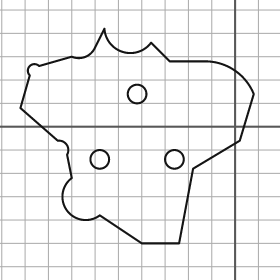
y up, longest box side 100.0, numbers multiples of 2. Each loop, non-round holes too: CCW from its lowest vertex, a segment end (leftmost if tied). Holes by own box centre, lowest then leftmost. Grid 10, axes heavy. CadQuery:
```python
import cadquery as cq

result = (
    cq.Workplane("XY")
    .moveTo(-40.0, -50.0)
    .lineTo(-24.0, -50.0)
    .lineTo(-18.0, -18.0)
    .lineTo(2.0, -6.0)
    .lineTo(8.0, 14.0)
    .threePointArc((0.0, 24.0), (-12.0, 28.0))
    .lineTo(-28.0, 28.0)
    .lineTo(-36.0, 36.0)
    .threePointArc((-48.0, 32.0), (-56.0, 42.0))
    .lineTo(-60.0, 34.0)
    .threePointArc((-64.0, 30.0), (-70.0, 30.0))
    .lineTo(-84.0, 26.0)
    .threePointArc((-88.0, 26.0), (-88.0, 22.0))
    .lineTo(-92.0, 8.0)
    .lineTo(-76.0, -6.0)
    .threePointArc((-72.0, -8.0), (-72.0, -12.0))
    .lineTo(-70.0, -22.0)
    .threePointArc((-72.0, -36.0), (-58.0, -38.0))
    .close()
    .moveTo(-58.0, -14.0)
    .circle(4.0)
    .moveTo(-26.0, -14.0)
    .circle(4.0)
    .moveTo(-42.0, 14.0)
    .circle(4.0)
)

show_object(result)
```